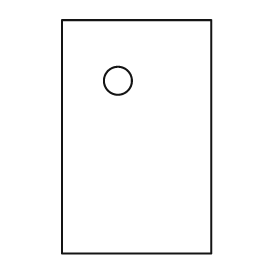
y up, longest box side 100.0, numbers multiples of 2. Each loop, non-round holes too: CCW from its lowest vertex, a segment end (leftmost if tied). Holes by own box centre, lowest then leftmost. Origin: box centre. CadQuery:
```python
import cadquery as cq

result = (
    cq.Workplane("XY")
    .moveTo(-32.0, -50.0)
    .lineTo(32.0, -50.0)
    .lineTo(32.0, 50.0)
    .lineTo(-32.0, 50.0)
    .close()
    .moveTo(-8.0, 24.0)
    .circle(6.0)
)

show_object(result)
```